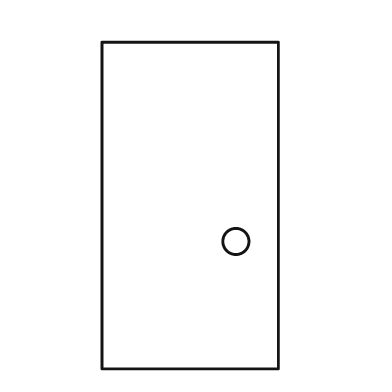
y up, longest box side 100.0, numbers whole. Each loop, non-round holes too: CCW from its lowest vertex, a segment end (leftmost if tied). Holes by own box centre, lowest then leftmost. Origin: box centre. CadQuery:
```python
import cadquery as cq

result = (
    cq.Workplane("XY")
    .moveTo(-27.0, -50.0)
    .lineTo(27.0, -50.0)
    .lineTo(27.0, 50.0)
    .lineTo(-27.0, 50.0)
    .close()
    .moveTo(14.0, -11.0)
    .circle(4.0)
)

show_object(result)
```